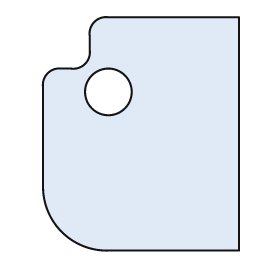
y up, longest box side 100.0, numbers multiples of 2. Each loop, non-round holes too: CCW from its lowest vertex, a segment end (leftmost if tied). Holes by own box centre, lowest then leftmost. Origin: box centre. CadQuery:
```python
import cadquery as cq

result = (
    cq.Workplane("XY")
    .moveTo(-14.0, -50.0)
    .lineTo(42.0, -50.0)
    .lineTo(42.0, 50.0)
    .lineTo(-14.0, 50.0)
    .threePointArc((-20.0, 48.0), (-22.0, 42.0))
    .lineTo(-22.0, 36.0)
    .threePointArc((-24.0, 30.0), (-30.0, 28.0))
    .lineTo(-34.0, 28.0)
    .threePointArc((-40.0, 26.0), (-42.0, 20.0))
    .lineTo(-42.0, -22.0)
    .threePointArc((-34.0, -42.0), (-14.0, -50.0))
    .close()
    .moveTo(-14.0, 18.0)
    .circle(10.0)
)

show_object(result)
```